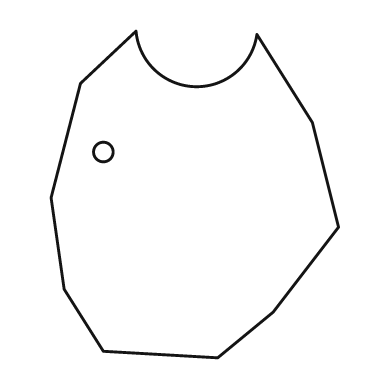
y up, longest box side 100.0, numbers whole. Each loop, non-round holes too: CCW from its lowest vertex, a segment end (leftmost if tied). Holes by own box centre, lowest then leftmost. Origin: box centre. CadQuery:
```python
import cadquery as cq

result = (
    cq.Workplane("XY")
    .moveTo(7.0, -50.0)
    .lineTo(24.0, -36.0)
    .lineTo(44.0, -10.0)
    .lineTo(36.0, 22.0)
    .lineTo(19.0, 49.0)
    .threePointArc((0.0, 33.0), (-18.0, 50.0))
    .lineTo(-35.0, 34.0)
    .lineTo(-44.0, -1.0)
    .lineTo(-40.0, -29.0)
    .lineTo(-28.0, -48.0)
    .close()
    .moveTo(-28.0, 13.0)
    .circle(3.0)
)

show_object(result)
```